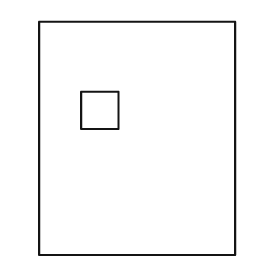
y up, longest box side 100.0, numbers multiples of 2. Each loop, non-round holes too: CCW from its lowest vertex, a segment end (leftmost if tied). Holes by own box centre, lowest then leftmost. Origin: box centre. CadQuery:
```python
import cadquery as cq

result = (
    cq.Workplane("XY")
    .moveTo(-42.0, -50.0)
    .lineTo(42.0, -50.0)
    .lineTo(42.0, 50.0)
    .lineTo(-42.0, 50.0)
    .close()
    .moveTo(-24.0, 4.0)
    .lineTo(-8.0, 4.0)
    .lineTo(-8.0, 20.0)
    .lineTo(-24.0, 20.0)
    .close()
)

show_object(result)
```